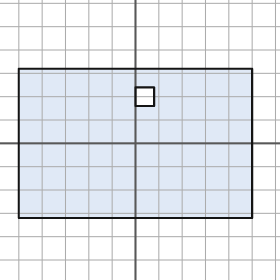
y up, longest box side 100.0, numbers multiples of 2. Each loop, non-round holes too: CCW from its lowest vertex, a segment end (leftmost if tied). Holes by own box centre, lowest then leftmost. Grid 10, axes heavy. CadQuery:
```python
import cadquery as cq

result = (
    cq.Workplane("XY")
    .moveTo(-50.0, -32.0)
    .lineTo(50.0, -32.0)
    .lineTo(50.0, 32.0)
    .lineTo(-50.0, 32.0)
    .close()
    .moveTo(0.0, 16.0)
    .lineTo(8.0, 16.0)
    .lineTo(8.0, 24.0)
    .lineTo(0.0, 24.0)
    .close()
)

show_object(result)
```